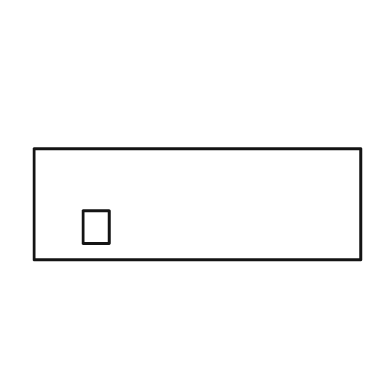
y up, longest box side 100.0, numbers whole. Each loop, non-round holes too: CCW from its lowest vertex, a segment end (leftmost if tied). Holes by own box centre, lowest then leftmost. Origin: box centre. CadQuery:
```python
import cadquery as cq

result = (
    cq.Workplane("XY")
    .moveTo(-50.0, -17.0)
    .lineTo(50.0, -17.0)
    .lineTo(50.0, 17.0)
    .lineTo(-50.0, 17.0)
    .close()
    .moveTo(-35.0, -12.0)
    .lineTo(-27.0, -12.0)
    .lineTo(-27.0, -2.0)
    .lineTo(-35.0, -2.0)
    .close()
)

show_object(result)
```